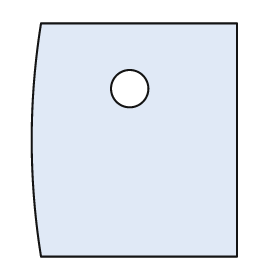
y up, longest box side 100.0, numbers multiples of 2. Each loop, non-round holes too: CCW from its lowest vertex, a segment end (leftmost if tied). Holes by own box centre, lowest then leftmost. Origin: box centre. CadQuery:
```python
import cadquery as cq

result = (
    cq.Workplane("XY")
    .moveTo(-40.0, -50.0)
    .lineTo(44.0, -50.0)
    .lineTo(44.0, 50.0)
    .lineTo(-40.0, 50.0)
    .threePointArc((-44.0, 0.0), (-40.0, -50.0))
    .close()
    .moveTo(-2.0, 22.0)
    .circle(8.0)
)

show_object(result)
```